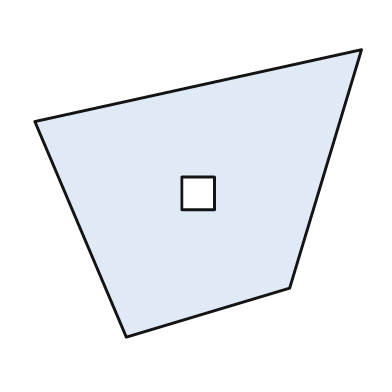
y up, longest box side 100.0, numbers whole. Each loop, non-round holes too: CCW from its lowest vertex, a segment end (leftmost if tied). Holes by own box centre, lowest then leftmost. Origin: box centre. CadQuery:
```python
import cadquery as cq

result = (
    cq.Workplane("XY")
    .moveTo(-22.0, -44.0)
    .lineTo(28.0, -29.0)
    .lineTo(50.0, 44.0)
    .lineTo(-50.0, 22.0)
    .close()
    .moveTo(-5.0, -5.0)
    .lineTo(5.0, -5.0)
    .lineTo(5.0, 5.0)
    .lineTo(-5.0, 5.0)
    .close()
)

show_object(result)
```